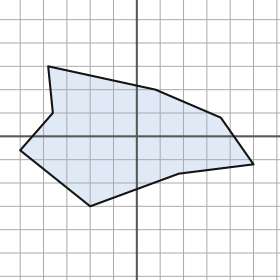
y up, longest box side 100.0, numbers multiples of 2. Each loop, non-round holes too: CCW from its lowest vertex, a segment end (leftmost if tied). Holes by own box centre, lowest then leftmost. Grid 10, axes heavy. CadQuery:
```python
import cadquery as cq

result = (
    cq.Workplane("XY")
    .moveTo(-20.0, -30.0)
    .lineTo(18.0, -16.0)
    .lineTo(50.0, -12.0)
    .lineTo(36.0, 8.0)
    .lineTo(8.0, 20.0)
    .lineTo(-38.0, 30.0)
    .lineTo(-36.0, 10.0)
    .lineTo(-50.0, -6.0)
    .close()
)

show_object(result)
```